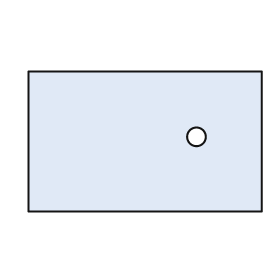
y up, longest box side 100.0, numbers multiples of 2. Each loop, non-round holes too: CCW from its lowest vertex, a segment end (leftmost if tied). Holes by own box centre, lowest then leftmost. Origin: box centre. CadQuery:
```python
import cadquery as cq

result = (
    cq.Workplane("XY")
    .moveTo(-50.0, -30.0)
    .lineTo(50.0, -30.0)
    .lineTo(50.0, 30.0)
    .lineTo(-50.0, 30.0)
    .close()
    .moveTo(22.0, 2.0)
    .circle(4.0)
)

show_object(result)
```